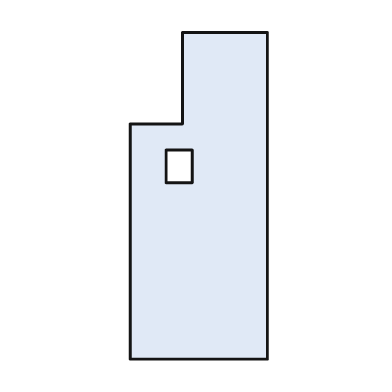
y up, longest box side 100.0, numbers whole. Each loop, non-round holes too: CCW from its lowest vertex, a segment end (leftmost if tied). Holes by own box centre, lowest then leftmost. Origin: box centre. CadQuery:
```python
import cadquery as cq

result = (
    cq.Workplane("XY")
    .moveTo(-21.0, -50.0)
    .lineTo(21.0, -50.0)
    .lineTo(21.0, 50.0)
    .lineTo(-5.0, 50.0)
    .lineTo(-5.0, 22.0)
    .lineTo(-21.0, 22.0)
    .close()
    .moveTo(-10.0, 4.0)
    .lineTo(-2.0, 4.0)
    .lineTo(-2.0, 14.0)
    .lineTo(-10.0, 14.0)
    .close()
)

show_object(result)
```